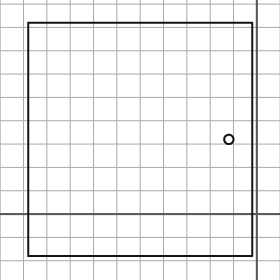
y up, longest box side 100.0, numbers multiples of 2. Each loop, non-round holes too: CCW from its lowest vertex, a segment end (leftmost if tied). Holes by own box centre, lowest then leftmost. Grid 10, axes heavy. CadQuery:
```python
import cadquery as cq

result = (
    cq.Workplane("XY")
    .moveTo(-98.0, -18.0)
    .lineTo(-2.0, -18.0)
    .lineTo(-2.0, 82.0)
    .lineTo(-98.0, 82.0)
    .close()
    .moveTo(-12.0, 32.0)
    .circle(2.0)
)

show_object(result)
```